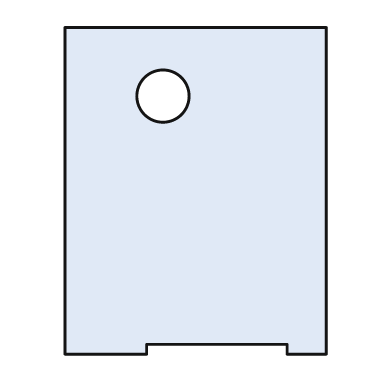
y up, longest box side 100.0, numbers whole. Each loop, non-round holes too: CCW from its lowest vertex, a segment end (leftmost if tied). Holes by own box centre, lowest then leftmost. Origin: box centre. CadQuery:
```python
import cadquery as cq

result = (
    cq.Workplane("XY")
    .moveTo(-40.0, -50.0)
    .lineTo(-15.0, -50.0)
    .lineTo(-15.0, -47.0)
    .lineTo(28.0, -47.0)
    .lineTo(28.0, -50.0)
    .lineTo(40.0, -50.0)
    .lineTo(40.0, 50.0)
    .lineTo(-40.0, 50.0)
    .close()
    .moveTo(-10.0, 29.0)
    .circle(8.0)
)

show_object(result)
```